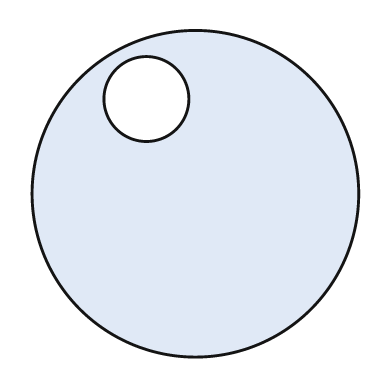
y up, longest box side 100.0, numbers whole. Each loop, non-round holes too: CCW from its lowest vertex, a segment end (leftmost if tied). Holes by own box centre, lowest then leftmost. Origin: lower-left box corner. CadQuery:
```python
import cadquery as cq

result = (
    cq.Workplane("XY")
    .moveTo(50.0, 50.0)
    .circle(50.0)
    .moveTo(35.0, 79.0)
    .circle(13.0)
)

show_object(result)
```